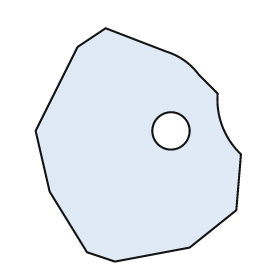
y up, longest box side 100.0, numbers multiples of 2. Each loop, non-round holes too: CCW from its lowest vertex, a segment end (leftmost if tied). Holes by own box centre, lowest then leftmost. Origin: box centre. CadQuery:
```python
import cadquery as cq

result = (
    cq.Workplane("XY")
    .moveTo(-10.0, -50.0)
    .lineTo(22.0, -44.0)
    .lineTo(42.0, -28.0)
    .lineTo(44.0, -4.0)
    .threePointArc((36.0, 8.0), (34.0, 22.0))
    .lineTo(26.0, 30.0)
    .threePointArc((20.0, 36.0), (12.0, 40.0))
    .lineTo(-14.0, 50.0)
    .lineTo(-26.0, 42.0)
    .lineTo(-44.0, 6.0)
    .lineTo(-38.0, -20.0)
    .lineTo(-22.0, -46.0)
    .close()
    .moveTo(14.0, 6.0)
    .circle(8.0)
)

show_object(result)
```